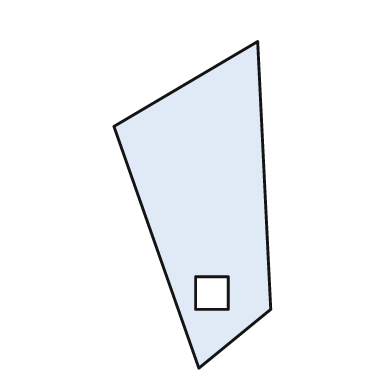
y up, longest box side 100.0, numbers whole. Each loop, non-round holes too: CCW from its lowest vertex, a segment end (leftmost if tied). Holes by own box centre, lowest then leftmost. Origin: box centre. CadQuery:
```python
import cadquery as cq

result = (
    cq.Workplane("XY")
    .moveTo(2.0, -50.0)
    .lineTo(24.0, -32.0)
    .lineTo(20.0, 50.0)
    .lineTo(-24.0, 24.0)
    .close()
    .moveTo(1.0, -32.0)
    .lineTo(11.0, -32.0)
    .lineTo(11.0, -22.0)
    .lineTo(1.0, -22.0)
    .close()
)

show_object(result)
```